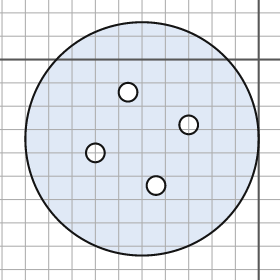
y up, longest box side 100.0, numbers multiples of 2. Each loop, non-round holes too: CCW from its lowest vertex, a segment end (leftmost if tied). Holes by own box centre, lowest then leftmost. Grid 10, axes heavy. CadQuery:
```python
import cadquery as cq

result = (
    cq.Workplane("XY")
    .moveTo(-50.0, -34.0)
    .circle(50.0)
    .moveTo(-44.0, -54.0)
    .circle(4.0)
    .moveTo(-70.0, -40.0)
    .circle(4.0)
    .moveTo(-30.0, -28.0)
    .circle(4.0)
    .moveTo(-56.0, -14.0)
    .circle(4.0)
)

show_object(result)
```